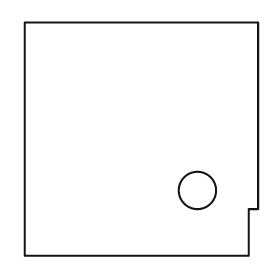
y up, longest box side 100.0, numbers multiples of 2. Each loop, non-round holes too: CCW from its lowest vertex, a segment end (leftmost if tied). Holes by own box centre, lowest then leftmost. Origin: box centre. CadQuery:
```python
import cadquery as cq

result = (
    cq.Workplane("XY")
    .moveTo(-50.0, -50.0)
    .lineTo(46.0, -50.0)
    .lineTo(46.0, -30.0)
    .lineTo(50.0, -30.0)
    .lineTo(50.0, 50.0)
    .lineTo(-50.0, 50.0)
    .close()
    .moveTo(24.0, -22.0)
    .circle(8.0)
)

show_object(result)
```